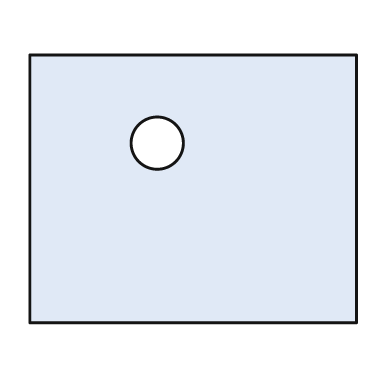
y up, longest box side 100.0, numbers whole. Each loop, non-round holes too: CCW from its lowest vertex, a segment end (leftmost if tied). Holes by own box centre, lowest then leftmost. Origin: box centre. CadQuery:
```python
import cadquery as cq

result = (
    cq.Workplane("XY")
    .moveTo(-50.0, -41.0)
    .lineTo(50.0, -41.0)
    .lineTo(50.0, 41.0)
    .lineTo(-50.0, 41.0)
    .close()
    .moveTo(-11.0, 14.0)
    .circle(8.0)
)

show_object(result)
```